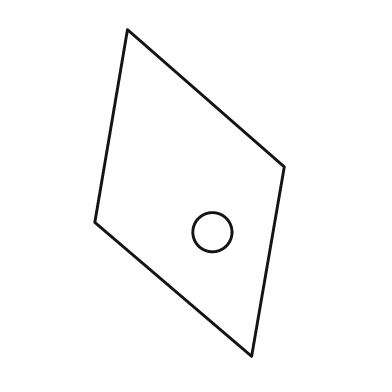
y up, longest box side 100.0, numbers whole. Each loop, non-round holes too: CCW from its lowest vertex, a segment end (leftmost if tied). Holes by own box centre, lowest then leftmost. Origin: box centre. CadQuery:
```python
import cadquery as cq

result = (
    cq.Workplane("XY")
    .moveTo(19.0, -50.0)
    .lineTo(29.0, 8.0)
    .lineTo(-19.0, 50.0)
    .lineTo(-29.0, -9.0)
    .close()
    .moveTo(7.0, -12.0)
    .circle(6.0)
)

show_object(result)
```